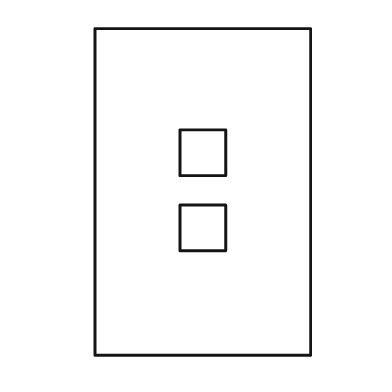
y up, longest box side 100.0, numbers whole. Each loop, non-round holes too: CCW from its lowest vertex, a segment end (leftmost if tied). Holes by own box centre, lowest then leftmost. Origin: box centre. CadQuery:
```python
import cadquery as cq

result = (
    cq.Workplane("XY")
    .moveTo(-33.0, -50.0)
    .lineTo(33.0, -50.0)
    .lineTo(33.0, 50.0)
    .lineTo(-33.0, 50.0)
    .close()
    .moveTo(-7.0, -18.0)
    .lineTo(7.0, -18.0)
    .lineTo(7.0, -4.0)
    .lineTo(-7.0, -4.0)
    .close()
    .moveTo(-7.0, 5.0)
    .lineTo(7.0, 5.0)
    .lineTo(7.0, 19.0)
    .lineTo(-7.0, 19.0)
    .close()
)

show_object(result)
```